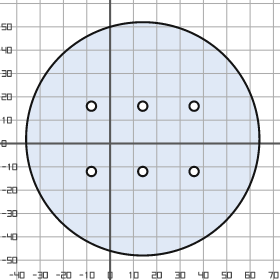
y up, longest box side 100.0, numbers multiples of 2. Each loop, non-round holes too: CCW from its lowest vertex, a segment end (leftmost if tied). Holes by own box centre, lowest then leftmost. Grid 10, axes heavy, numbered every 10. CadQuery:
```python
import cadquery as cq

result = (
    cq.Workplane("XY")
    .moveTo(14.0, 2.0)
    .circle(50.0)
    .moveTo(-8.0, -12.0)
    .circle(2.0)
    .moveTo(14.0, -12.0)
    .circle(2.0)
    .moveTo(36.0, -12.0)
    .circle(2.0)
    .moveTo(-8.0, 16.0)
    .circle(2.0)
    .moveTo(14.0, 16.0)
    .circle(2.0)
    .moveTo(36.0, 16.0)
    .circle(2.0)
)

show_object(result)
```